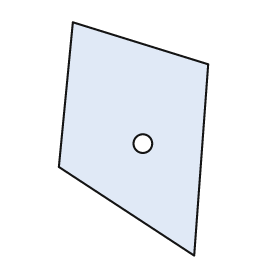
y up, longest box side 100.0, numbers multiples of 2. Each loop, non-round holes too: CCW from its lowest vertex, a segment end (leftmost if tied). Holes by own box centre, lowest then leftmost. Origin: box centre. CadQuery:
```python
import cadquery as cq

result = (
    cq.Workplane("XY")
    .moveTo(26.0, -50.0)
    .lineTo(32.0, 32.0)
    .lineTo(-26.0, 50.0)
    .lineTo(-32.0, -12.0)
    .close()
    .moveTo(4.0, -2.0)
    .circle(4.0)
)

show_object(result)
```